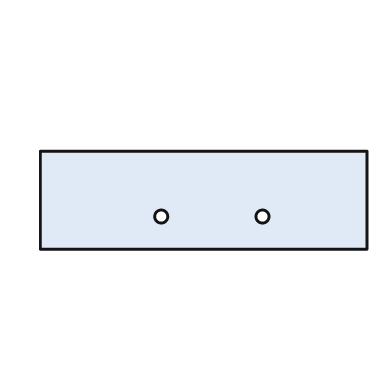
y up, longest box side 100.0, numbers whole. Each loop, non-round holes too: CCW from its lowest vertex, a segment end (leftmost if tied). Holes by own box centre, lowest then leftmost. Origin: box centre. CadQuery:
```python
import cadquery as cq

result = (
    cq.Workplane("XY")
    .moveTo(-50.0, -15.0)
    .lineTo(50.0, -15.0)
    .lineTo(50.0, 15.0)
    .lineTo(-50.0, 15.0)
    .close()
    .moveTo(-13.0, -5.0)
    .circle(2.0)
    .moveTo(18.0, -5.0)
    .circle(2.0)
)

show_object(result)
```